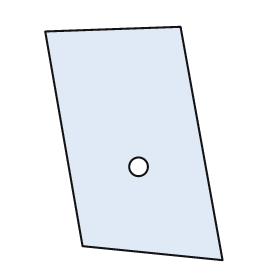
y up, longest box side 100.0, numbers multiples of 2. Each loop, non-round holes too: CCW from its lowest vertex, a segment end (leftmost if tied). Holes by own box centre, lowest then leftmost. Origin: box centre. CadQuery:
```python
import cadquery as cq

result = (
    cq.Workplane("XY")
    .moveTo(38.0, -50.0)
    .lineTo(20.0, 50.0)
    .lineTo(-38.0, 48.0)
    .lineTo(-22.0, -44.0)
    .close()
    .moveTo(2.0, -10.0)
    .circle(4.0)
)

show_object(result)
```